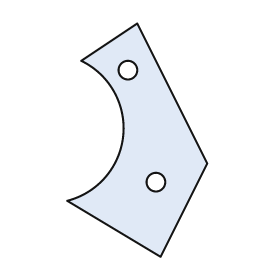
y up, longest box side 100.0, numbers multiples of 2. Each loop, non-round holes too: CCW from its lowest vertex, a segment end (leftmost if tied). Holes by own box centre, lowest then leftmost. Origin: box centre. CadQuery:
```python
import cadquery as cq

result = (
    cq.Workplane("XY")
    .moveTo(10.0, -50.0)
    .lineTo(30.0, -10.0)
    .lineTo(0.0, 50.0)
    .lineTo(-24.0, 34.0)
    .threePointArc((-6.0, 2.0), (-30.0, -26.0))
    .close()
    .moveTo(8.0, -18.0)
    .circle(4.0)
    .moveTo(-4.0, 30.0)
    .circle(4.0)
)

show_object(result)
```